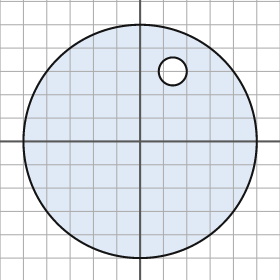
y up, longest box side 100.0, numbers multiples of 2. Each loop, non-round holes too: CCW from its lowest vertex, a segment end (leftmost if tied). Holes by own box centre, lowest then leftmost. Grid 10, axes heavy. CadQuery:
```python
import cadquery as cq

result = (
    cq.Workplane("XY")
    .moveTo(0.0, 0.0)
    .circle(50.0)
    .moveTo(14.0, 30.0)
    .circle(6.0)
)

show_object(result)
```